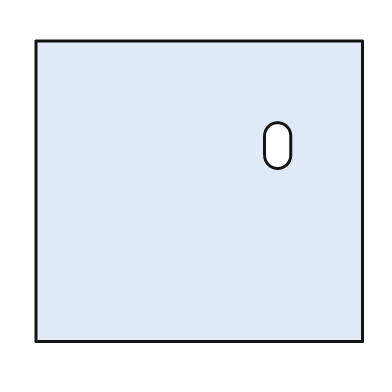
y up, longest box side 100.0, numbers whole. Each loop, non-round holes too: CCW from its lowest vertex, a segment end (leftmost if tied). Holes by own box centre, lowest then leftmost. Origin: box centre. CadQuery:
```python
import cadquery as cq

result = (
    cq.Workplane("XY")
    .moveTo(-50.0, -46.0)
    .lineTo(50.0, -46.0)
    .lineTo(50.0, 46.0)
    .lineTo(-50.0, 46.0)
    .close()
    .moveTo(20.0, 11.0)
    .threePointArc((24.0, 7.0), (28.0, 11.0))
    .lineTo(28.0, 17.0)
    .threePointArc((24.0, 21.0), (20.0, 17.0))
    .close()
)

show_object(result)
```